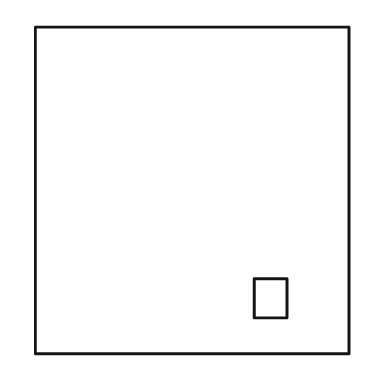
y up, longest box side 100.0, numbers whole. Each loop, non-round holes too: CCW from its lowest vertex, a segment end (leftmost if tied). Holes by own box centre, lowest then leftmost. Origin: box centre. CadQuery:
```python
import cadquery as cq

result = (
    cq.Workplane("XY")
    .moveTo(-48.0, -50.0)
    .lineTo(48.0, -50.0)
    .lineTo(48.0, 50.0)
    .lineTo(-48.0, 50.0)
    .close()
    .moveTo(19.0, -39.0)
    .lineTo(29.0, -39.0)
    .lineTo(29.0, -27.0)
    .lineTo(19.0, -27.0)
    .close()
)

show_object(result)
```